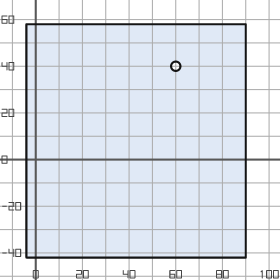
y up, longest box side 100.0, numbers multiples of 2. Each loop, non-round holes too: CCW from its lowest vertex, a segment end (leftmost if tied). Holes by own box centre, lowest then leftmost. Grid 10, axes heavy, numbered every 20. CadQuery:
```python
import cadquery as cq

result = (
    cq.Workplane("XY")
    .moveTo(-4.0, -42.0)
    .lineTo(90.0, -42.0)
    .lineTo(90.0, 58.0)
    .lineTo(-4.0, 58.0)
    .close()
    .moveTo(60.0, 40.0)
    .circle(2.0)
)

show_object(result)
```